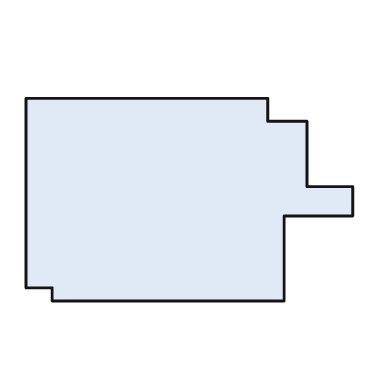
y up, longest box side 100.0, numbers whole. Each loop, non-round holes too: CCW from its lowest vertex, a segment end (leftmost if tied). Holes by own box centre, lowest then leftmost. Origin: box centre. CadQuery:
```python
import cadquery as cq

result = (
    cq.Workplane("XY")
    .moveTo(-42.0, -31.0)
    .lineTo(29.0, -31.0)
    .lineTo(29.0, -5.0)
    .lineTo(50.0, -5.0)
    .lineTo(50.0, 4.0)
    .lineTo(36.0, 4.0)
    .lineTo(36.0, 24.0)
    .lineTo(24.0, 24.0)
    .lineTo(24.0, 31.0)
    .lineTo(-50.0, 31.0)
    .lineTo(-50.0, -27.0)
    .lineTo(-42.0, -27.0)
    .close()
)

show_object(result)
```